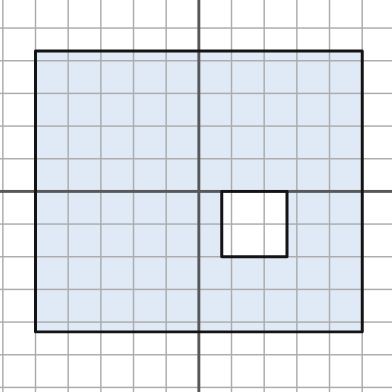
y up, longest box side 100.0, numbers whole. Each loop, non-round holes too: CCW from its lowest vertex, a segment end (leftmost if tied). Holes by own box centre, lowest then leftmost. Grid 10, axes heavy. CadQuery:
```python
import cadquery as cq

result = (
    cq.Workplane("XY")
    .moveTo(-50.0, -43.0)
    .lineTo(50.0, -43.0)
    .lineTo(50.0, 43.0)
    .lineTo(-50.0, 43.0)
    .close()
    .moveTo(7.0, -20.0)
    .lineTo(27.0, -20.0)
    .lineTo(27.0, 0.0)
    .lineTo(7.0, 0.0)
    .close()
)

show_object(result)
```